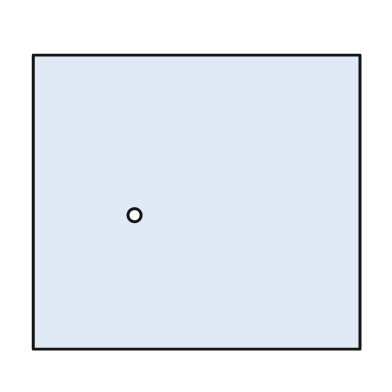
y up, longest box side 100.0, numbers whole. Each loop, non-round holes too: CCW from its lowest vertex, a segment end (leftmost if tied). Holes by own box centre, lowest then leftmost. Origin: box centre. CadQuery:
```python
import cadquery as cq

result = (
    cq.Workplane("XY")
    .moveTo(-50.0, -45.0)
    .lineTo(50.0, -45.0)
    .lineTo(50.0, 45.0)
    .lineTo(-50.0, 45.0)
    .close()
    .moveTo(-19.0, -4.0)
    .circle(2.0)
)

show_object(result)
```